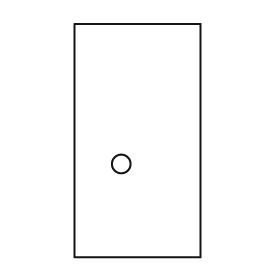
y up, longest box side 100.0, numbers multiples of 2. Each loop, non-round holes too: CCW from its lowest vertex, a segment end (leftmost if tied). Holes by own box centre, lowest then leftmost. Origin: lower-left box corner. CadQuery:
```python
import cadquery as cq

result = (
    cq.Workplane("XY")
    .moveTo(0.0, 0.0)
    .lineTo(54.0, 0.0)
    .lineTo(54.0, 100.0)
    .lineTo(0.0, 100.0)
    .close()
    .moveTo(20.0, 40.0)
    .circle(4.0)
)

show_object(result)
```